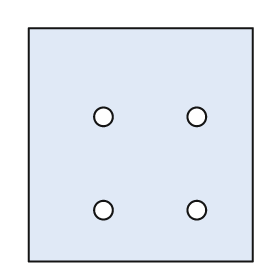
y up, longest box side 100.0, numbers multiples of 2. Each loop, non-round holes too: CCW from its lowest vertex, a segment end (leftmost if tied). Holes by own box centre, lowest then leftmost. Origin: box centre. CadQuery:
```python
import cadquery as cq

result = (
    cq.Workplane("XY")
    .moveTo(-48.0, -50.0)
    .lineTo(48.0, -50.0)
    .lineTo(48.0, 50.0)
    .lineTo(-48.0, 50.0)
    .close()
    .moveTo(-16.0, -28.0)
    .circle(4.0)
    .moveTo(24.0, -28.0)
    .circle(4.0)
    .moveTo(-16.0, 12.0)
    .circle(4.0)
    .moveTo(24.0, 12.0)
    .circle(4.0)
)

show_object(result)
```